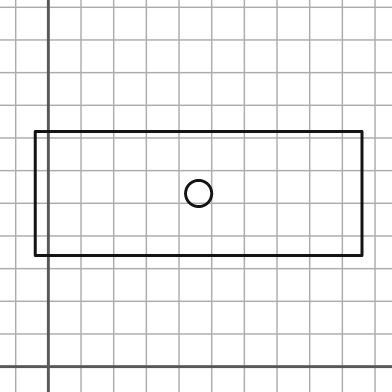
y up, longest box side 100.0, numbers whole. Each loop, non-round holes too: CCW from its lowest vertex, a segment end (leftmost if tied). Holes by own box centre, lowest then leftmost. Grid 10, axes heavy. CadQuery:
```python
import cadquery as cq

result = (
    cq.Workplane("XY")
    .moveTo(-4.0, 34.0)
    .lineTo(96.0, 34.0)
    .lineTo(96.0, 72.0)
    .lineTo(-4.0, 72.0)
    .close()
    .moveTo(46.0, 53.0)
    .circle(4.0)
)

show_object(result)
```